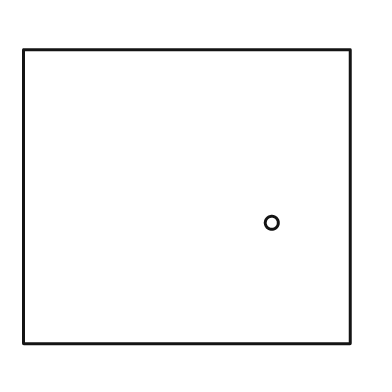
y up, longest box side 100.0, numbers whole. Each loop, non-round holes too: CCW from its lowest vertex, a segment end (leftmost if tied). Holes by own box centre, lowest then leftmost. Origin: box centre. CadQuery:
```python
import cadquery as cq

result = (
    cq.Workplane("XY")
    .moveTo(-50.0, -45.0)
    .lineTo(50.0, -45.0)
    .lineTo(50.0, 45.0)
    .lineTo(-50.0, 45.0)
    .close()
    .moveTo(26.0, -8.0)
    .circle(2.0)
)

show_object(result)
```